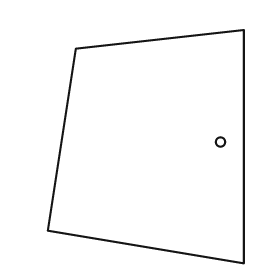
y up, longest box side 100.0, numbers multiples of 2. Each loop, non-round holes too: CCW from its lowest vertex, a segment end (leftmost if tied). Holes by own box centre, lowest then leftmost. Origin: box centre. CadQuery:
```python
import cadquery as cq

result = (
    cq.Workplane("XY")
    .moveTo(42.0, -50.0)
    .lineTo(42.0, 50.0)
    .lineTo(-30.0, 42.0)
    .lineTo(-42.0, -36.0)
    .close()
    .moveTo(32.0, 2.0)
    .circle(2.0)
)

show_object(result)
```